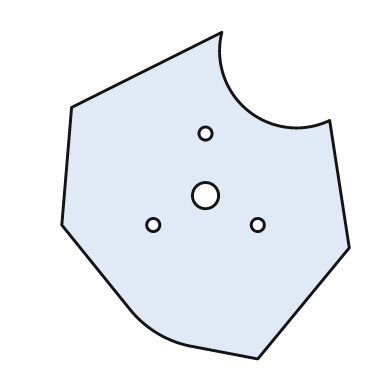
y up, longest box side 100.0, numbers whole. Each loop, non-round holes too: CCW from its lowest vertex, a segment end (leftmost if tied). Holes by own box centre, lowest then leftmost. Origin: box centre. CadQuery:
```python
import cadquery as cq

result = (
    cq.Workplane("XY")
    .moveTo(16.0, -50.0)
    .lineTo(44.0, -16.0)
    .lineTo(38.0, 23.0)
    .threePointArc((13.0, 26.0), (5.0, 50.0))
    .lineTo(-41.0, 27.0)
    .lineTo(-44.0, -9.0)
    .lineTo(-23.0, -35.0)
    .threePointArc((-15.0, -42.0), (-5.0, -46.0))
    .close()
    .moveTo(-16.0, -9.0)
    .circle(2.0)
    .moveTo(16.0, -9.0)
    .circle(2.0)
    .moveTo(0.0, 0.0)
    .circle(4.0)
    .moveTo(0.0, 19.0)
    .circle(2.0)
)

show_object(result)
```